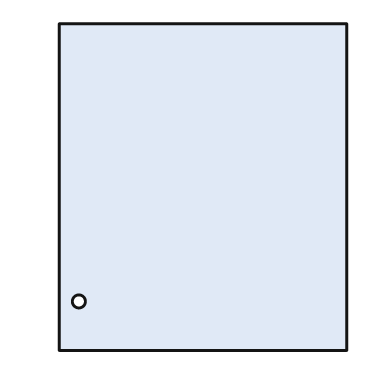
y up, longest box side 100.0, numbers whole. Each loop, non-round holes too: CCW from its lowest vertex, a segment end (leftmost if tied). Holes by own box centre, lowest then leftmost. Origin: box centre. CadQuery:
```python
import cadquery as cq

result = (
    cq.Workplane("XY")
    .moveTo(-44.0, -50.0)
    .lineTo(44.0, -50.0)
    .lineTo(44.0, 50.0)
    .lineTo(-44.0, 50.0)
    .close()
    .moveTo(-38.0, -35.0)
    .circle(2.0)
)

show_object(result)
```